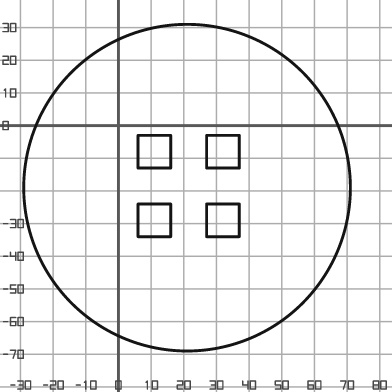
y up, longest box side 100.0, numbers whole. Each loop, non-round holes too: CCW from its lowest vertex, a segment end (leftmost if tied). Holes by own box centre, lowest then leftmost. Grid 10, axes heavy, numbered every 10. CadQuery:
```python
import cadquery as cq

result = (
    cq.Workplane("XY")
    .moveTo(21.0, -19.0)
    .circle(50.0)
    .moveTo(6.0, -34.0)
    .lineTo(16.0, -34.0)
    .lineTo(16.0, -24.0)
    .lineTo(6.0, -24.0)
    .close()
    .moveTo(27.0, -34.0)
    .lineTo(37.0, -34.0)
    .lineTo(37.0, -24.0)
    .lineTo(27.0, -24.0)
    .close()
    .moveTo(6.0, -13.0)
    .lineTo(16.0, -13.0)
    .lineTo(16.0, -3.0)
    .lineTo(6.0, -3.0)
    .close()
    .moveTo(27.0, -13.0)
    .lineTo(37.0, -13.0)
    .lineTo(37.0, -3.0)
    .lineTo(27.0, -3.0)
    .close()
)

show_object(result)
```